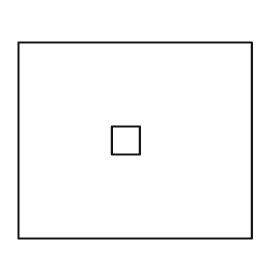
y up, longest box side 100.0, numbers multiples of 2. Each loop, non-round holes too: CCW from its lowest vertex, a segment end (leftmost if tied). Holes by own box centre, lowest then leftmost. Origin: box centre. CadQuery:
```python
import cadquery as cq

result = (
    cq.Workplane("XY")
    .moveTo(-50.0, -42.0)
    .lineTo(50.0, -42.0)
    .lineTo(50.0, 42.0)
    .lineTo(-50.0, 42.0)
    .close()
    .moveTo(-10.0, -6.0)
    .lineTo(2.0, -6.0)
    .lineTo(2.0, 6.0)
    .lineTo(-10.0, 6.0)
    .close()
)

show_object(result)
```